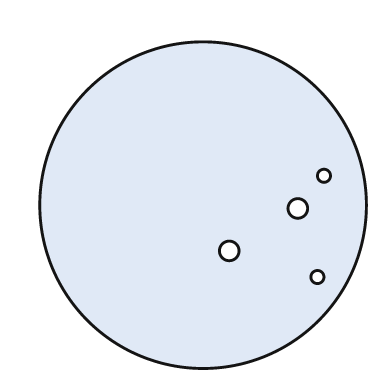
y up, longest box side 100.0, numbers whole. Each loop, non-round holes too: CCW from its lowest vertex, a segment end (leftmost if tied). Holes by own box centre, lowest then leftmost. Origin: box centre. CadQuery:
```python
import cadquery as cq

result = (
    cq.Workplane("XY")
    .moveTo(0.0, 0.0)
    .circle(50.0)
    .moveTo(35.0, -22.0)
    .circle(2.0)
    .moveTo(8.0, -14.0)
    .circle(3.0)
    .moveTo(29.0, -1.0)
    .circle(3.0)
    .moveTo(37.0, 9.0)
    .circle(2.0)
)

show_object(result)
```